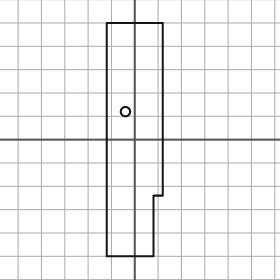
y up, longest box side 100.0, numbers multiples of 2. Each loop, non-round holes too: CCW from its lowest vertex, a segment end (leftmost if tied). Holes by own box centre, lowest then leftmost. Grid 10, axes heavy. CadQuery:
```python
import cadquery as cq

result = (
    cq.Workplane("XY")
    .moveTo(-12.0, -50.0)
    .lineTo(8.0, -50.0)
    .lineTo(8.0, -24.0)
    .lineTo(12.0, -24.0)
    .lineTo(12.0, 50.0)
    .lineTo(-12.0, 50.0)
    .close()
    .moveTo(-4.0, 12.0)
    .circle(2.0)
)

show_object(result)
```